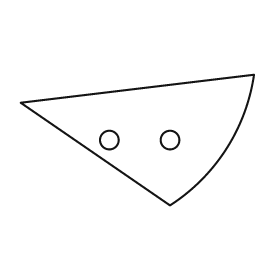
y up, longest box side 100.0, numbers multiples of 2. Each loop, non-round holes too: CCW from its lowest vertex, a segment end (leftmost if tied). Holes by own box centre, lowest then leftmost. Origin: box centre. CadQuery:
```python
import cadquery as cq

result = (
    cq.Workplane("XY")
    .moveTo(14.0, -28.0)
    .threePointArc((38.0, -4.0), (50.0, 28.0))
    .lineTo(-50.0, 16.0)
    .close()
    .moveTo(-12.0, 0.0)
    .circle(4.0)
    .moveTo(14.0, 0.0)
    .circle(4.0)
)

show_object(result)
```